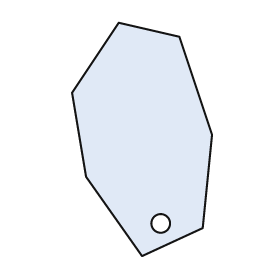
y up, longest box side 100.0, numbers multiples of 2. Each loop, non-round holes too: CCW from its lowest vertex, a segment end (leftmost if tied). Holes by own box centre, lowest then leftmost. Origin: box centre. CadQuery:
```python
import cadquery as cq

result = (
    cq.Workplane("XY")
    .moveTo(0.0, -50.0)
    .lineTo(26.0, -38.0)
    .lineTo(30.0, 2.0)
    .lineTo(16.0, 44.0)
    .lineTo(-10.0, 50.0)
    .lineTo(-30.0, 20.0)
    .lineTo(-24.0, -16.0)
    .close()
    .moveTo(8.0, -36.0)
    .circle(4.0)
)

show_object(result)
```